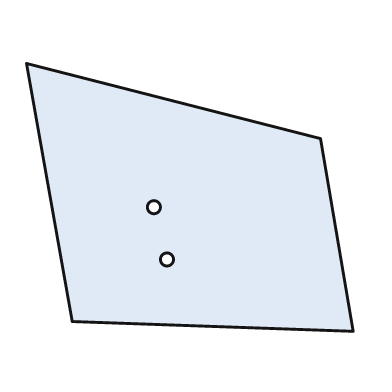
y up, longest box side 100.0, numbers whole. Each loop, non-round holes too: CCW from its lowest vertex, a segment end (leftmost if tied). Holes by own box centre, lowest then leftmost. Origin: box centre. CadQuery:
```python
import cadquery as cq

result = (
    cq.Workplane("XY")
    .moveTo(50.0, -41.0)
    .lineTo(40.0, 18.0)
    .lineTo(-50.0, 41.0)
    .lineTo(-36.0, -38.0)
    .close()
    .moveTo(-7.0, -19.0)
    .circle(2.0)
    .moveTo(-11.0, -3.0)
    .circle(2.0)
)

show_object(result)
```